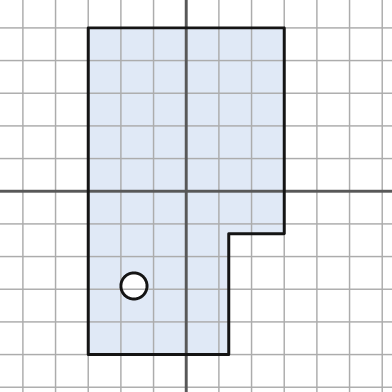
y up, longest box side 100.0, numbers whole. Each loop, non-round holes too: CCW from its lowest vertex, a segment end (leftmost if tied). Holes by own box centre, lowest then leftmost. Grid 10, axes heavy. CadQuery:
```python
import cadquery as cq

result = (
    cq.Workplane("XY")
    .moveTo(-30.0, -50.0)
    .lineTo(13.0, -50.0)
    .lineTo(13.0, -13.0)
    .lineTo(30.0, -13.0)
    .lineTo(30.0, 50.0)
    .lineTo(-30.0, 50.0)
    .close()
    .moveTo(-16.0, -29.0)
    .circle(4.0)
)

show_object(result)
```